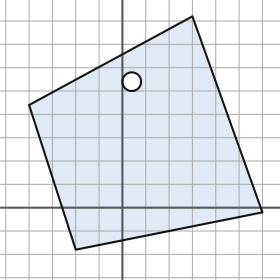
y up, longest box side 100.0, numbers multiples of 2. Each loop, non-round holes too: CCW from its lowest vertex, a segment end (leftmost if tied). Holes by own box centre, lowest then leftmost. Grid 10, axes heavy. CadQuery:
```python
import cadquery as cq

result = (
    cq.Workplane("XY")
    .moveTo(-20.0, -18.0)
    .lineTo(60.0, -2.0)
    .lineTo(30.0, 82.0)
    .lineTo(-40.0, 44.0)
    .close()
    .moveTo(4.0, 54.0)
    .circle(4.0)
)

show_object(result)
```